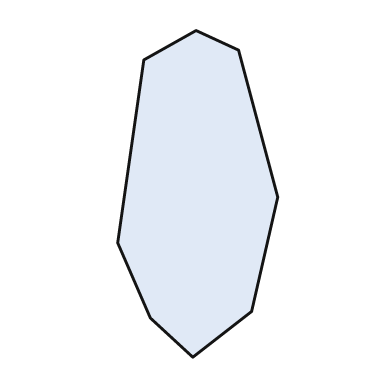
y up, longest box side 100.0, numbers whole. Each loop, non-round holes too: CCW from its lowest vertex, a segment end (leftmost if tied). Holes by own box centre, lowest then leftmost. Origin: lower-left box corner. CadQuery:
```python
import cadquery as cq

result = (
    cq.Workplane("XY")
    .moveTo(23.0, 0.0)
    .lineTo(41.0, 14.0)
    .lineTo(49.0, 49.0)
    .lineTo(37.0, 94.0)
    .lineTo(24.0, 100.0)
    .lineTo(8.0, 91.0)
    .lineTo(0.0, 35.0)
    .lineTo(10.0, 12.0)
    .close()
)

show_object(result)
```